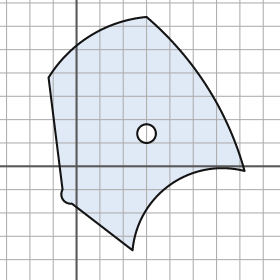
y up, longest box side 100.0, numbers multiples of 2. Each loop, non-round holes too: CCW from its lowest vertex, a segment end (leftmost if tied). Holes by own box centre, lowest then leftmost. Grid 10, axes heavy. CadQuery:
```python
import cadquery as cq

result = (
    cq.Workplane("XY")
    .moveTo(24.0, -36.0)
    .threePointArc((40.0, -8.0), (72.0, -2.0))
    .threePointArc((56.0, 34.0), (30.0, 64.0))
    .threePointArc((6.0, 56.0), (-12.0, 38.0))
    .lineTo(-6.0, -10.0)
    .threePointArc((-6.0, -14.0), (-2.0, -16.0))
    .close()
    .moveTo(30.0, 14.0)
    .circle(4.0)
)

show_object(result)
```